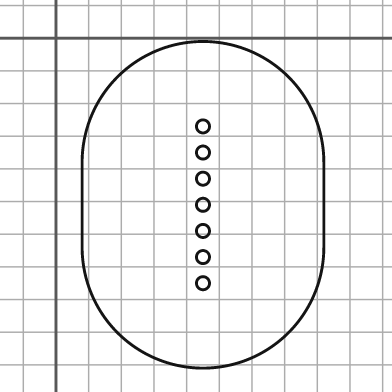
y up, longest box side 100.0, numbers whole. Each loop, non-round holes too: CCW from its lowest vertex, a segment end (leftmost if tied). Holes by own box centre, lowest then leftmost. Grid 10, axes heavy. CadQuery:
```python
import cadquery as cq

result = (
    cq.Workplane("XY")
    .moveTo(8.0, -64.0)
    .threePointArc((45.0, -101.0), (82.0, -64.0))
    .lineTo(82.0, -38.0)
    .threePointArc((45.0, -1.0), (8.0, -38.0))
    .close()
    .moveTo(45.0, -75.0)
    .circle(2.0)
    .moveTo(45.0, -67.0)
    .circle(2.0)
    .moveTo(45.0, -59.0)
    .circle(2.0)
    .moveTo(45.0, -51.0)
    .circle(2.0)
    .moveTo(45.0, -43.0)
    .circle(2.0)
    .moveTo(45.0, -35.0)
    .circle(2.0)
    .moveTo(45.0, -27.0)
    .circle(2.0)
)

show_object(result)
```